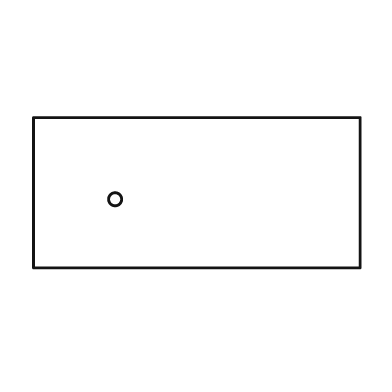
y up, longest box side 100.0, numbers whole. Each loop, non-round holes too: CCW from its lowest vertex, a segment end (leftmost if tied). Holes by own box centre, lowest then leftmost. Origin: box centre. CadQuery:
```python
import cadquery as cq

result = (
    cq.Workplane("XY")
    .moveTo(-50.0, -23.0)
    .lineTo(50.0, -23.0)
    .lineTo(50.0, 23.0)
    .lineTo(-50.0, 23.0)
    .close()
    .moveTo(-25.0, -2.0)
    .circle(2.0)
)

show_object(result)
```